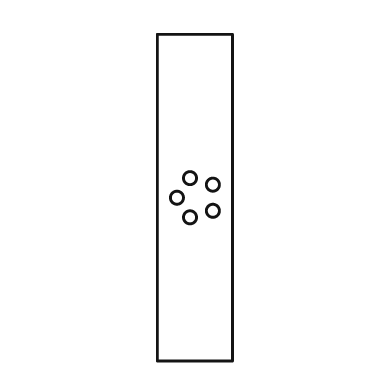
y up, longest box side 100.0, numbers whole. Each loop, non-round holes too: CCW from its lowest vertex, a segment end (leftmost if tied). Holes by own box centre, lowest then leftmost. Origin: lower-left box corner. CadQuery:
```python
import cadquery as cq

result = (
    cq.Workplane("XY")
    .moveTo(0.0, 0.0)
    .lineTo(23.0, 0.0)
    .lineTo(23.0, 100.0)
    .lineTo(0.0, 100.0)
    .close()
    .moveTo(10.0, 44.0)
    .circle(2.0)
    .moveTo(17.0, 46.0)
    .circle(2.0)
    .moveTo(6.0, 50.0)
    .circle(2.0)
    .moveTo(17.0, 54.0)
    .circle(2.0)
    .moveTo(10.0, 56.0)
    .circle(2.0)
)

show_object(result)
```